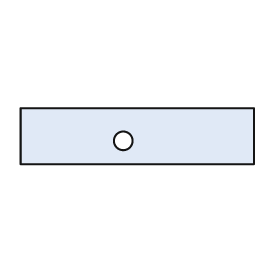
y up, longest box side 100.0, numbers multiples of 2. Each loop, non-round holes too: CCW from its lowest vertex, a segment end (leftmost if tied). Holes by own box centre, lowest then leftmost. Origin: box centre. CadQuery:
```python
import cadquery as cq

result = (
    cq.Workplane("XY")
    .moveTo(-50.0, -12.0)
    .lineTo(50.0, -12.0)
    .lineTo(50.0, 12.0)
    .lineTo(-50.0, 12.0)
    .close()
    .moveTo(-6.0, -2.0)
    .circle(4.0)
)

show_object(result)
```